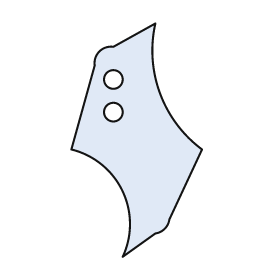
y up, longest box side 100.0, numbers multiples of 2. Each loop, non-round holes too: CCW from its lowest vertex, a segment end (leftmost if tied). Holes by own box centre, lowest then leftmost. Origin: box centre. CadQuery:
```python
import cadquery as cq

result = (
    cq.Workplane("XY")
    .moveTo(-6.0, -50.0)
    .lineTo(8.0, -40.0)
    .threePointArc((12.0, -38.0), (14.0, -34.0))
    .lineTo(28.0, -4.0)
    .threePointArc((10.0, 20.0), (8.0, 50.0))
    .lineTo(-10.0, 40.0)
    .threePointArc((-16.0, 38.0), (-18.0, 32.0))
    .lineTo(-28.0, -4.0)
    .threePointArc((-6.0, -22.0), (-6.0, -50.0))
    .close()
    .moveTo(-10.0, 12.0)
    .circle(4.0)
    .moveTo(-10.0, 26.0)
    .circle(4.0)
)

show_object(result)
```